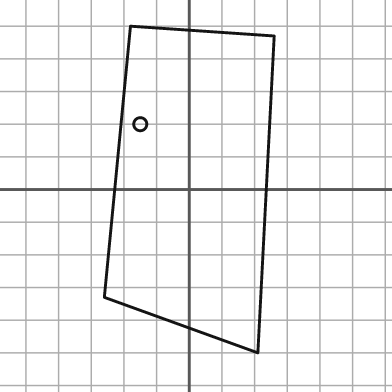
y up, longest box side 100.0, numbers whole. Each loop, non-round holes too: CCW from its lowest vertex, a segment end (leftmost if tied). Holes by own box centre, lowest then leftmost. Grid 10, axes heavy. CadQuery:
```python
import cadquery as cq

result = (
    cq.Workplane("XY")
    .moveTo(21.0, -50.0)
    .lineTo(26.0, 47.0)
    .lineTo(-18.0, 50.0)
    .lineTo(-26.0, -33.0)
    .close()
    .moveTo(-15.0, 20.0)
    .circle(2.0)
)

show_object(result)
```